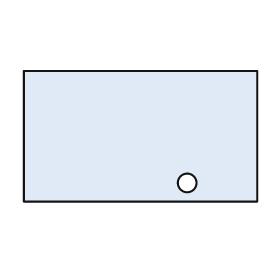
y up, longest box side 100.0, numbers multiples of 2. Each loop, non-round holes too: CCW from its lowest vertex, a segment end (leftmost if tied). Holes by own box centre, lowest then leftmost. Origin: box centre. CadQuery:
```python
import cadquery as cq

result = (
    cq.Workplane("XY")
    .moveTo(-50.0, -28.0)
    .lineTo(50.0, -28.0)
    .lineTo(50.0, 28.0)
    .lineTo(-50.0, 28.0)
    .close()
    .moveTo(20.0, -20.0)
    .circle(4.0)
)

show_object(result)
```